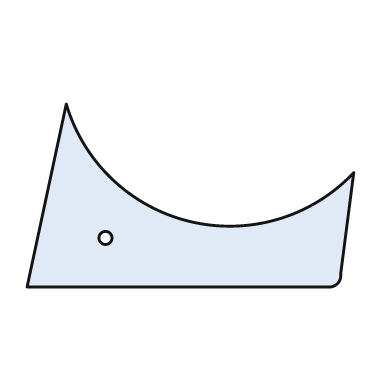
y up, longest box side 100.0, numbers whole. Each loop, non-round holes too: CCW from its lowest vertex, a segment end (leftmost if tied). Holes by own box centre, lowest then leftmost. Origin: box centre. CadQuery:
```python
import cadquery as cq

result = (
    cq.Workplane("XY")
    .moveTo(-50.0, -28.0)
    .lineTo(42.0, -28.0)
    .threePointArc((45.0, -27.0), (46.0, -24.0))
    .lineTo(50.0, 7.0)
    .threePointArc((0.0, -8.0), (-38.0, 28.0))
    .close()
    .moveTo(-26.0, -13.0)
    .circle(2.0)
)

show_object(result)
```